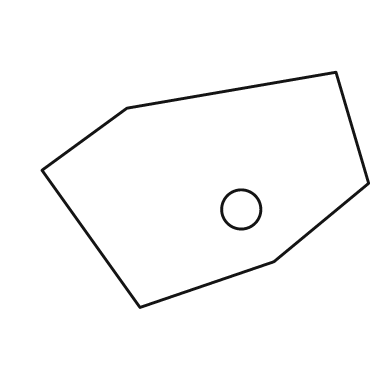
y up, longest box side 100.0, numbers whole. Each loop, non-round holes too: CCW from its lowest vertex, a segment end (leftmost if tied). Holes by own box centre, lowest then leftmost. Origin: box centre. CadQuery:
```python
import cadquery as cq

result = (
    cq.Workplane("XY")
    .moveTo(-20.0, -36.0)
    .lineTo(21.0, -22.0)
    .lineTo(50.0, 2.0)
    .lineTo(40.0, 36.0)
    .lineTo(-24.0, 25.0)
    .lineTo(-50.0, 6.0)
    .close()
    .moveTo(11.0, -6.0)
    .circle(6.0)
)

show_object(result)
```